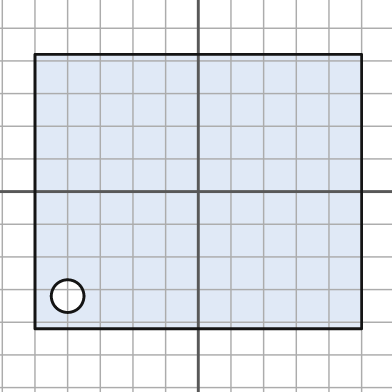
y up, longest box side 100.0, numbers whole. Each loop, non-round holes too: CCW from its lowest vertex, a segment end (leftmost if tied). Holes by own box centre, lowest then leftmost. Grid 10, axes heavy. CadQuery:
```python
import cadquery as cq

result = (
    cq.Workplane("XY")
    .moveTo(-50.0, -42.0)
    .lineTo(50.0, -42.0)
    .lineTo(50.0, 42.0)
    .lineTo(-50.0, 42.0)
    .close()
    .moveTo(-40.0, -32.0)
    .circle(5.0)
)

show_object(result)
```